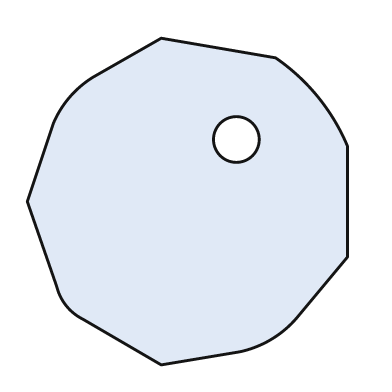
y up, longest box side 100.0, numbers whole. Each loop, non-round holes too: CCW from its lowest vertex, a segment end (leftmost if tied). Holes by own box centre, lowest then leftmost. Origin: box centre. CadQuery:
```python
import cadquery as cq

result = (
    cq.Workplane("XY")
    .moveTo(-8.0, -50.0)
    .lineTo(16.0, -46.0)
    .threePointArc((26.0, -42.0), (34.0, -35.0))
    .lineTo(49.0, -17.0)
    .lineTo(49.0, 17.0)
    .threePointArc((40.0, 32.0), (27.0, 44.0))
    .lineTo(-8.0, 50.0)
    .lineTo(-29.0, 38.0)
    .threePointArc((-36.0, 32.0), (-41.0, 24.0))
    .lineTo(-49.0, 0.0)
    .lineTo(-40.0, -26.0)
    .threePointArc((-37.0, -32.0), (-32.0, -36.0))
    .close()
    .moveTo(15.0, 19.0)
    .circle(7.0)
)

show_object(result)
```